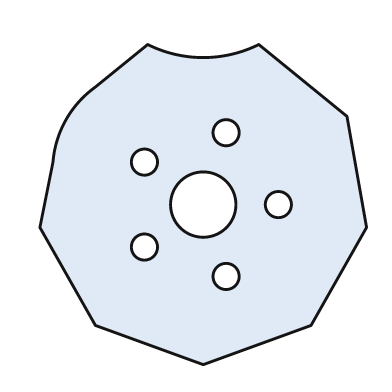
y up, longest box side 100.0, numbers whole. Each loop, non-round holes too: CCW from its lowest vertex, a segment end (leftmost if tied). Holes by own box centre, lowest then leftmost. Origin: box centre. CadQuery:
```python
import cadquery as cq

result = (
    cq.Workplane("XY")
    .moveTo(0.0, -49.0)
    .lineTo(33.0, -37.0)
    .lineTo(50.0, -7.0)
    .lineTo(44.0, 27.0)
    .lineTo(17.0, 49.0)
    .threePointArc((0.0, 45.0), (-17.0, 49.0))
    .lineTo(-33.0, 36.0)
    .threePointArc((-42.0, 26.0), (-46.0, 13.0))
    .lineTo(-50.0, -7.0)
    .lineTo(-33.0, -37.0)
    .close()
    .moveTo(7.0, -22.0)
    .circle(4.0)
    .moveTo(-18.0, -13.0)
    .circle(4.0)
    .moveTo(0.0, 0.0)
    .circle(10.0)
    .moveTo(23.0, 0.0)
    .circle(4.0)
    .moveTo(-18.0, 13.0)
    .circle(4.0)
    .moveTo(7.0, 22.0)
    .circle(4.0)
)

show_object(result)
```